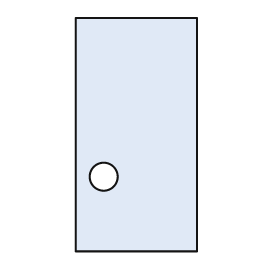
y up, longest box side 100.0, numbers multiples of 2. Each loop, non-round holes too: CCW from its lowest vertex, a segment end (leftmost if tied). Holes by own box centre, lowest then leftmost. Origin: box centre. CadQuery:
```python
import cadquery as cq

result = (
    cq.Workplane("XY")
    .moveTo(-26.0, -50.0)
    .lineTo(26.0, -50.0)
    .lineTo(26.0, 50.0)
    .lineTo(-26.0, 50.0)
    .close()
    .moveTo(-14.0, -18.0)
    .circle(6.0)
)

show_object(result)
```